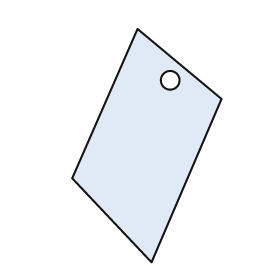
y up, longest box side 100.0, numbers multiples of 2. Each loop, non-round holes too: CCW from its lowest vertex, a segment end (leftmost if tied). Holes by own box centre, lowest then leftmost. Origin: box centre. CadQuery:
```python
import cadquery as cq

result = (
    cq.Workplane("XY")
    .moveTo(2.0, -50.0)
    .lineTo(32.0, 20.0)
    .lineTo(-4.0, 50.0)
    .lineTo(-32.0, -14.0)
    .close()
    .moveTo(10.0, 28.0)
    .circle(4.0)
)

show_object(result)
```